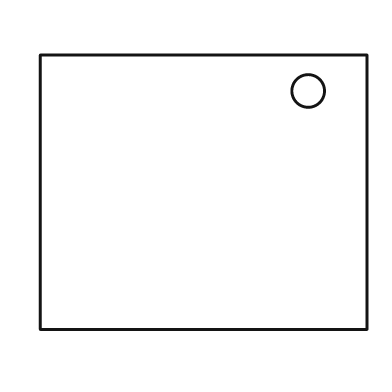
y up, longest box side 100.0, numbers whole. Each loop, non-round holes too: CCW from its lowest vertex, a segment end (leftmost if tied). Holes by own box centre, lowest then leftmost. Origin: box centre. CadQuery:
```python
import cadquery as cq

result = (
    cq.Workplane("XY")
    .moveTo(-50.0, -42.0)
    .lineTo(50.0, -42.0)
    .lineTo(50.0, 42.0)
    .lineTo(-50.0, 42.0)
    .close()
    .moveTo(32.0, 31.0)
    .circle(5.0)
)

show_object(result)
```